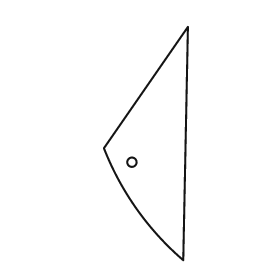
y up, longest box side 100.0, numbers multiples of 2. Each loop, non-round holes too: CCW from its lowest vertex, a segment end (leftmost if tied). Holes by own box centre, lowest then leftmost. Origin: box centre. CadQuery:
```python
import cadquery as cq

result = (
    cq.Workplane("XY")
    .moveTo(16.0, -50.0)
    .lineTo(18.0, 50.0)
    .lineTo(-18.0, -2.0)
    .threePointArc((-4.0, -28.0), (16.0, -50.0))
    .close()
    .moveTo(-6.0, -8.0)
    .circle(2.0)
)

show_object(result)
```